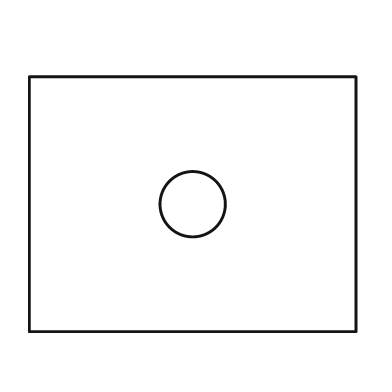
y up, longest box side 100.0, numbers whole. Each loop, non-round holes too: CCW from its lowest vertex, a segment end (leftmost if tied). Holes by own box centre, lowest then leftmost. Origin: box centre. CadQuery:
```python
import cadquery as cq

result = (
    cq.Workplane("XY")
    .moveTo(-50.0, -39.0)
    .lineTo(50.0, -39.0)
    .lineTo(50.0, 39.0)
    .lineTo(-50.0, 39.0)
    .close()
    .moveTo(0.0, 0.0)
    .circle(10.0)
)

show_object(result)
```